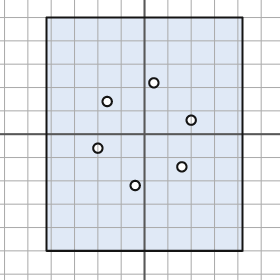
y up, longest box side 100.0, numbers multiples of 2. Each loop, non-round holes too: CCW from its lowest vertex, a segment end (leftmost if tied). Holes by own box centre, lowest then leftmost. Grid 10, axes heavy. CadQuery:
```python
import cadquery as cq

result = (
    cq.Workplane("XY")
    .moveTo(-42.0, -50.0)
    .lineTo(42.0, -50.0)
    .lineTo(42.0, 50.0)
    .lineTo(-42.0, 50.0)
    .close()
    .moveTo(-4.0, -22.0)
    .circle(2.0)
    .moveTo(16.0, -14.0)
    .circle(2.0)
    .moveTo(-20.0, -6.0)
    .circle(2.0)
    .moveTo(20.0, 6.0)
    .circle(2.0)
    .moveTo(-16.0, 14.0)
    .circle(2.0)
    .moveTo(4.0, 22.0)
    .circle(2.0)
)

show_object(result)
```